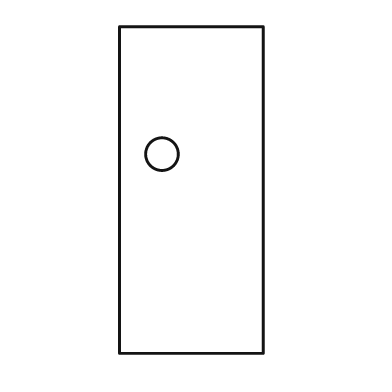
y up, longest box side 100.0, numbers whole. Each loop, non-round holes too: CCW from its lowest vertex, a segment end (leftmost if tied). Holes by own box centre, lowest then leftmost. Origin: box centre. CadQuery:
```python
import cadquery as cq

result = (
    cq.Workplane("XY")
    .moveTo(-22.0, -50.0)
    .lineTo(22.0, -50.0)
    .lineTo(22.0, 50.0)
    .lineTo(-22.0, 50.0)
    .close()
    .moveTo(-9.0, 11.0)
    .circle(5.0)
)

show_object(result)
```